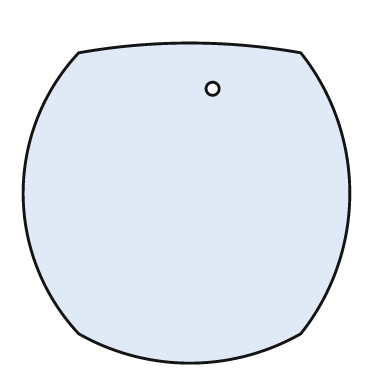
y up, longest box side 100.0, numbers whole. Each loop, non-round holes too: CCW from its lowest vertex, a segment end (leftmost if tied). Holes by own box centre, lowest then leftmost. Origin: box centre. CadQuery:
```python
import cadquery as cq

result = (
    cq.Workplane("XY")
    .moveTo(-33.0, -40.0)
    .threePointArc((1.0, -49.0), (35.0, -40.0))
    .threePointArc((50.0, 3.0), (35.0, 46.0))
    .threePointArc((1.0, 49.0), (-33.0, 46.0))
    .threePointArc((-50.0, 3.0), (-33.0, -40.0))
    .close()
    .moveTo(8.0, 35.0)
    .circle(2.0)
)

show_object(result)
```